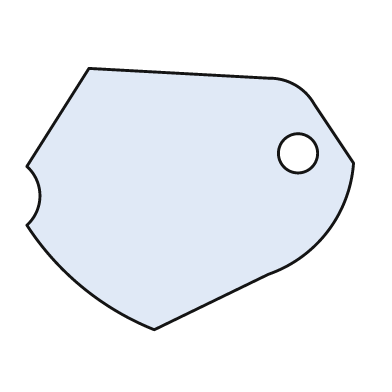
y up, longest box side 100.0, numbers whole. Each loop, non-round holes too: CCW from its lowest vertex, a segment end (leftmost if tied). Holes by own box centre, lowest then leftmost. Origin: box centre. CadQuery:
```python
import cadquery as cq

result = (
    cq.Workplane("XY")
    .moveTo(-11.0, -40.0)
    .lineTo(24.0, -23.0)
    .threePointArc((42.0, -10.0), (50.0, 11.0))
    .lineTo(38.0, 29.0)
    .threePointArc((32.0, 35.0), (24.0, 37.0))
    .lineTo(-31.0, 40.0)
    .lineTo(-50.0, 10.0)
    .threePointArc((-46.0, 1.0), (-50.0, -8.0))
    .threePointArc((-33.0, -27.0), (-11.0, -40.0))
    .close()
    .moveTo(33.0, 14.0)
    .circle(6.0)
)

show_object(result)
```